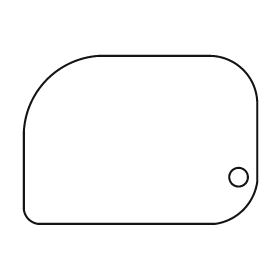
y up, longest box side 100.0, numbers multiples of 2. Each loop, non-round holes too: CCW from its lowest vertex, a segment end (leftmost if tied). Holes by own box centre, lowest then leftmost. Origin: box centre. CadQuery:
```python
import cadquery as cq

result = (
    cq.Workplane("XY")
    .moveTo(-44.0, -36.0)
    .lineTo(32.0, -36.0)
    .threePointArc((44.0, -30.0), (50.0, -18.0))
    .lineTo(50.0, 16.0)
    .threePointArc((44.0, 30.0), (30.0, 36.0))
    .lineTo(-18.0, 36.0)
    .threePointArc((-40.0, 26.0), (-50.0, 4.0))
    .lineTo(-50.0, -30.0)
    .threePointArc((-48.0, -34.0), (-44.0, -36.0))
    .close()
    .moveTo(42.0, -16.0)
    .circle(4.0)
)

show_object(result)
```